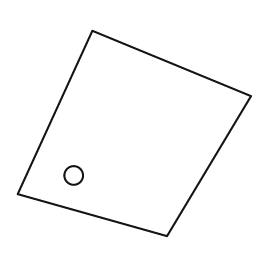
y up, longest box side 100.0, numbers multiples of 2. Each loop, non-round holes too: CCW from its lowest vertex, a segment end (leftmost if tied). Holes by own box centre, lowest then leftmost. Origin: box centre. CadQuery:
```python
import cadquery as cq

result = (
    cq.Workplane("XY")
    .moveTo(14.0, -44.0)
    .lineTo(50.0, 16.0)
    .lineTo(-18.0, 44.0)
    .lineTo(-50.0, -26.0)
    .close()
    .moveTo(-26.0, -18.0)
    .circle(4.0)
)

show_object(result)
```